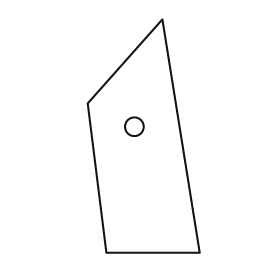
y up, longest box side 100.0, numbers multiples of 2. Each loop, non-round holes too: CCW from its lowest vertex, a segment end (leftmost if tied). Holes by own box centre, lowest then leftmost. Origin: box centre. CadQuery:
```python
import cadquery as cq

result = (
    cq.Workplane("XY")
    .moveTo(-16.0, -50.0)
    .lineTo(24.0, -50.0)
    .lineTo(8.0, 50.0)
    .lineTo(-24.0, 14.0)
    .close()
    .moveTo(-4.0, 4.0)
    .circle(4.0)
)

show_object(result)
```